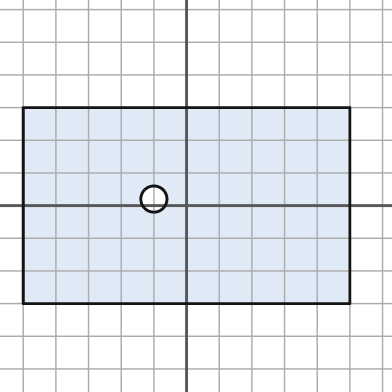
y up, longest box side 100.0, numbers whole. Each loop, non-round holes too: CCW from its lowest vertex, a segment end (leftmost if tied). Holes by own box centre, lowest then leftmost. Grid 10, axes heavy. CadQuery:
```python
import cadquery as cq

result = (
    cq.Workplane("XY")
    .moveTo(-50.0, -30.0)
    .lineTo(50.0, -30.0)
    .lineTo(50.0, 30.0)
    .lineTo(-50.0, 30.0)
    .close()
    .moveTo(-10.0, 2.0)
    .circle(4.0)
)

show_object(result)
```